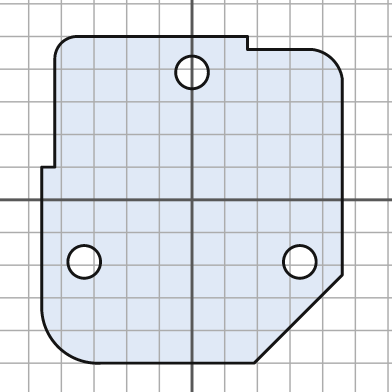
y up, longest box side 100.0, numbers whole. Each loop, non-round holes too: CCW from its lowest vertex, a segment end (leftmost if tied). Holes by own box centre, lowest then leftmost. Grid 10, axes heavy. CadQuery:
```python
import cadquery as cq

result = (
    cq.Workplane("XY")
    .moveTo(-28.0, -50.0)
    .lineTo(19.0, -50.0)
    .lineTo(46.0, -23.0)
    .lineTo(46.0, 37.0)
    .threePointArc((43.0, 43.0), (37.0, 46.0))
    .lineTo(17.0, 46.0)
    .lineTo(17.0, 50.0)
    .lineTo(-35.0, 50.0)
    .threePointArc((-40.0, 48.0), (-42.0, 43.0))
    .lineTo(-42.0, 10.0)
    .lineTo(-46.0, 10.0)
    .lineTo(-46.0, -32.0)
    .threePointArc((-41.0, -45.0), (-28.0, -50.0))
    .close()
    .moveTo(-33.0, -19.0)
    .circle(5.0)
    .moveTo(33.0, -19.0)
    .circle(5.0)
    .moveTo(0.0, 39.0)
    .circle(5.0)
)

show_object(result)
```